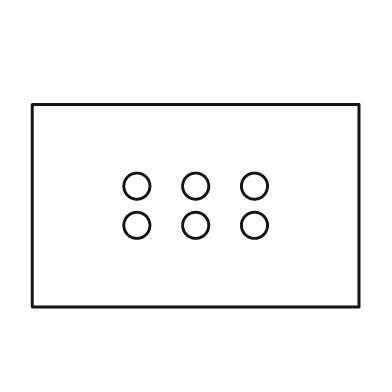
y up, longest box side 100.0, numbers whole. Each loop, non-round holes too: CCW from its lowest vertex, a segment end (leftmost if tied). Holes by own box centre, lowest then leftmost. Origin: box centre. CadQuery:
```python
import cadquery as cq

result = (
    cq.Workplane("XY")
    .moveTo(-50.0, -31.0)
    .lineTo(50.0, -31.0)
    .lineTo(50.0, 31.0)
    .lineTo(-50.0, 31.0)
    .close()
    .moveTo(-18.0, -6.0)
    .circle(4.0)
    .moveTo(0.0, -6.0)
    .circle(4.0)
    .moveTo(18.0, -6.0)
    .circle(4.0)
    .moveTo(-18.0, 6.0)
    .circle(4.0)
    .moveTo(0.0, 6.0)
    .circle(4.0)
    .moveTo(18.0, 6.0)
    .circle(4.0)
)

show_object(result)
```